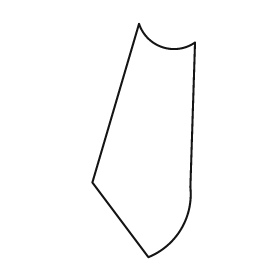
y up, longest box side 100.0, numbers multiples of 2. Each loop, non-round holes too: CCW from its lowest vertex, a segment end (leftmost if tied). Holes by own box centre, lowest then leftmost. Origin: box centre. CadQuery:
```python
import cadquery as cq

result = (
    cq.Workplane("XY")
    .moveTo(2.0, -50.0)
    .threePointArc((16.0, -38.0), (20.0, -20.0))
    .lineTo(22.0, 42.0)
    .threePointArc((8.0, 40.0), (-2.0, 50.0))
    .lineTo(-22.0, -18.0)
    .close()
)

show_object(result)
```